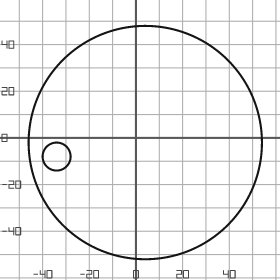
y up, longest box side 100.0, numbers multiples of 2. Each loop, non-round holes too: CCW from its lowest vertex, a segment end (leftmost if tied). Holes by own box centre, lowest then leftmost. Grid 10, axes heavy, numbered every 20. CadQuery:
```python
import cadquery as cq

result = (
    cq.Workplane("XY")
    .moveTo(4.0, -2.0)
    .circle(50.0)
    .moveTo(-34.0, -8.0)
    .circle(6.0)
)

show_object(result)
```